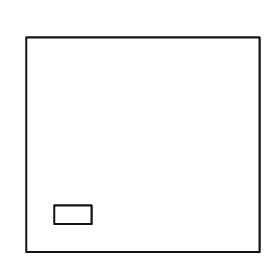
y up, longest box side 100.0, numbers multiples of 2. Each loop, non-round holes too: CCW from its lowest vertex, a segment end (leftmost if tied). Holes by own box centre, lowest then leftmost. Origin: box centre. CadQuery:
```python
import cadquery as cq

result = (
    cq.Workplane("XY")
    .moveTo(-50.0, -46.0)
    .lineTo(50.0, -46.0)
    .lineTo(50.0, 46.0)
    .lineTo(-50.0, 46.0)
    .close()
    .moveTo(-38.0, -34.0)
    .lineTo(-22.0, -34.0)
    .lineTo(-22.0, -26.0)
    .lineTo(-38.0, -26.0)
    .close()
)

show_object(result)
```